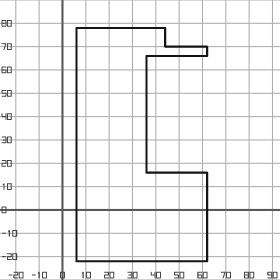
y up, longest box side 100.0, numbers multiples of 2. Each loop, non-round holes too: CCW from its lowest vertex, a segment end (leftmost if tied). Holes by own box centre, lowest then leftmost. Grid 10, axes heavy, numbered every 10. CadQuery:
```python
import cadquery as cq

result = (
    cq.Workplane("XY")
    .moveTo(6.0, -22.0)
    .lineTo(62.0, -22.0)
    .lineTo(62.0, 16.0)
    .lineTo(36.0, 16.0)
    .lineTo(36.0, 66.0)
    .lineTo(62.0, 66.0)
    .lineTo(62.0, 70.0)
    .lineTo(44.0, 70.0)
    .lineTo(44.0, 78.0)
    .lineTo(6.0, 78.0)
    .close()
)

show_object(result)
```